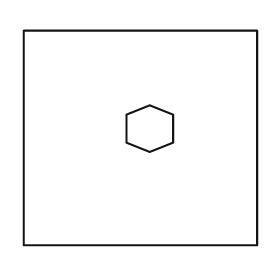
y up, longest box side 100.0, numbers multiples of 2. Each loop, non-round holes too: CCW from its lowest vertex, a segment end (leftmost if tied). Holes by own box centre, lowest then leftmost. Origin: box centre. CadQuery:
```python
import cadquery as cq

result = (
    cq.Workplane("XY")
    .moveTo(-50.0, -46.0)
    .lineTo(50.0, -46.0)
    .lineTo(50.0, 46.0)
    .lineTo(-50.0, 46.0)
    .close()
    .moveTo(4.0, -6.0)
    .lineTo(14.0, -2.0)
    .lineTo(14.0, 10.0)
    .lineTo(4.0, 14.0)
    .lineTo(-6.0, 10.0)
    .lineTo(-6.0, -2.0)
    .close()
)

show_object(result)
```